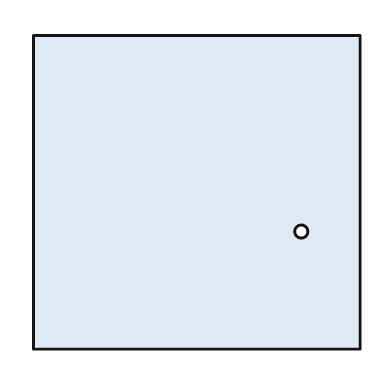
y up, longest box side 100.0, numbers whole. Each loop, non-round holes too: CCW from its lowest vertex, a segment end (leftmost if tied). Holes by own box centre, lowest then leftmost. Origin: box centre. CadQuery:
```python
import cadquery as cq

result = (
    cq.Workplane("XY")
    .moveTo(-50.0, -48.0)
    .lineTo(50.0, -48.0)
    .lineTo(50.0, 48.0)
    .lineTo(-50.0, 48.0)
    .close()
    .moveTo(32.0, -12.0)
    .circle(2.0)
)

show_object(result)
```